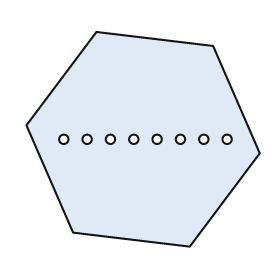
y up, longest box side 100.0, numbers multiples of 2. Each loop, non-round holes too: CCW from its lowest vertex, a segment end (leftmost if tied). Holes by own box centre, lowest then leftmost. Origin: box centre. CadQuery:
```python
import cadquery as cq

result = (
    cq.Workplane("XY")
    .moveTo(20.0, -46.0)
    .lineTo(50.0, -6.0)
    .lineTo(30.0, 40.0)
    .lineTo(-20.0, 46.0)
    .lineTo(-50.0, 6.0)
    .lineTo(-30.0, -40.0)
    .close()
    .moveTo(-34.0, 0.0)
    .circle(2.0)
    .moveTo(-24.0, 0.0)
    .circle(2.0)
    .moveTo(-14.0, 0.0)
    .circle(2.0)
    .moveTo(-4.0, 0.0)
    .circle(2.0)
    .moveTo(6.0, 0.0)
    .circle(2.0)
    .moveTo(16.0, 0.0)
    .circle(2.0)
    .moveTo(26.0, 0.0)
    .circle(2.0)
    .moveTo(36.0, 0.0)
    .circle(2.0)
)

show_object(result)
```